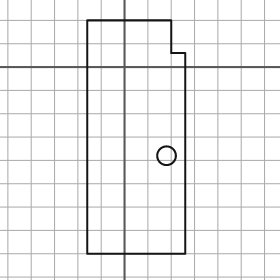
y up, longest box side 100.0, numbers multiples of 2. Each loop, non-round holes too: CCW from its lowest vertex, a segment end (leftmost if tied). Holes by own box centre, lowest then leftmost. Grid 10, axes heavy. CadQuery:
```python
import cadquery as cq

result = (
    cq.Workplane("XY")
    .moveTo(-16.0, -80.0)
    .lineTo(26.0, -80.0)
    .lineTo(26.0, 6.0)
    .lineTo(20.0, 6.0)
    .lineTo(20.0, 20.0)
    .lineTo(-16.0, 20.0)
    .close()
    .moveTo(18.0, -38.0)
    .circle(4.0)
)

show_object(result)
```